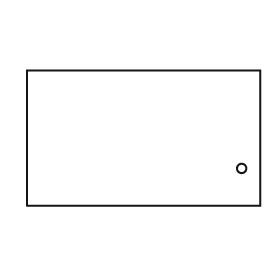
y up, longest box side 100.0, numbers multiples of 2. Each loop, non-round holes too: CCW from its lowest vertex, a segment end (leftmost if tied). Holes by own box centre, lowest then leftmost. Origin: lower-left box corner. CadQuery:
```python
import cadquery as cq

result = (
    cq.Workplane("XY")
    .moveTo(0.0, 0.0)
    .lineTo(100.0, 0.0)
    .lineTo(100.0, 58.0)
    .lineTo(0.0, 58.0)
    .close()
    .moveTo(92.0, 16.0)
    .circle(2.0)
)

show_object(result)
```